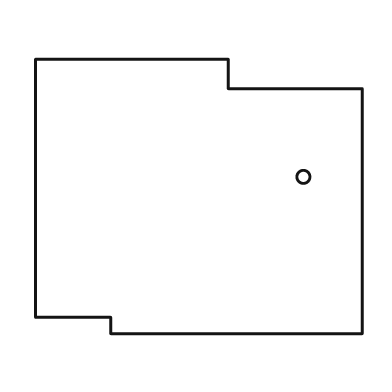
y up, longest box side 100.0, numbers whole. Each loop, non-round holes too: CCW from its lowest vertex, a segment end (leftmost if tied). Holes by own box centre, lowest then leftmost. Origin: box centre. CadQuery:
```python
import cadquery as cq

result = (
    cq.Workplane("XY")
    .moveTo(-27.0, -42.0)
    .lineTo(50.0, -42.0)
    .lineTo(50.0, 33.0)
    .lineTo(9.0, 33.0)
    .lineTo(9.0, 42.0)
    .lineTo(-50.0, 42.0)
    .lineTo(-50.0, -37.0)
    .lineTo(-27.0, -37.0)
    .close()
    .moveTo(32.0, 6.0)
    .circle(2.0)
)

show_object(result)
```